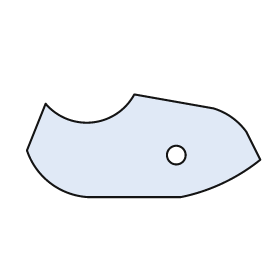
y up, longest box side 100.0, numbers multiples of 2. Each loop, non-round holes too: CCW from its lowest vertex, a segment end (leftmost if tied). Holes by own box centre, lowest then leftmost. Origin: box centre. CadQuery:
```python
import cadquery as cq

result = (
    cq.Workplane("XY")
    .moveTo(-24.0, -22.0)
    .lineTo(16.0, -22.0)
    .threePointArc((34.0, -16.0), (50.0, -6.0))
    .lineTo(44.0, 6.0)
    .threePointArc((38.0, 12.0), (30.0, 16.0))
    .lineTo(-4.0, 22.0)
    .threePointArc((-22.0, 10.0), (-42.0, 18.0))
    .lineTo(-50.0, -2.0)
    .threePointArc((-40.0, -16.0), (-24.0, -22.0))
    .close()
    .moveTo(14.0, -4.0)
    .circle(4.0)
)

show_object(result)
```